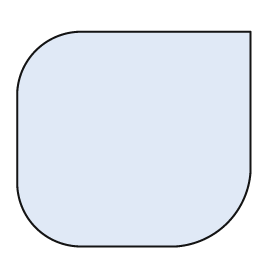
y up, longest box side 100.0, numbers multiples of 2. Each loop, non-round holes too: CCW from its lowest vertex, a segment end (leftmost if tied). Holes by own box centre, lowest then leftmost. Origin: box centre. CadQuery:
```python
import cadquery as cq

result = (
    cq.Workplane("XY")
    .moveTo(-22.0, -46.0)
    .lineTo(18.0, -46.0)
    .threePointArc((40.0, -36.0), (50.0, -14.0))
    .lineTo(50.0, 46.0)
    .lineTo(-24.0, 46.0)
    .threePointArc((-42.0, 38.0), (-50.0, 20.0))
    .lineTo(-50.0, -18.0)
    .threePointArc((-42.0, -38.0), (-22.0, -46.0))
    .close()
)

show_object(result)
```